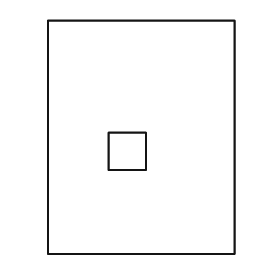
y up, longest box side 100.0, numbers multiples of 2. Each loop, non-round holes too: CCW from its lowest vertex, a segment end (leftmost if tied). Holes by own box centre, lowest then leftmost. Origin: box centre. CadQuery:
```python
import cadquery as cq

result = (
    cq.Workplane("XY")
    .moveTo(-40.0, -50.0)
    .lineTo(40.0, -50.0)
    .lineTo(40.0, 50.0)
    .lineTo(-40.0, 50.0)
    .close()
    .moveTo(-14.0, -14.0)
    .lineTo(2.0, -14.0)
    .lineTo(2.0, 2.0)
    .lineTo(-14.0, 2.0)
    .close()
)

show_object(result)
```